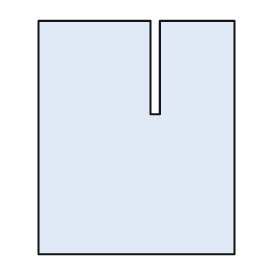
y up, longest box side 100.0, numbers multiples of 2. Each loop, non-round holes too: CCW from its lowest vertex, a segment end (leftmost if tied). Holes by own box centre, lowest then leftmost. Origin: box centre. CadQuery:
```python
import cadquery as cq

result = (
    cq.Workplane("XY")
    .moveTo(-42.0, -50.0)
    .lineTo(42.0, -50.0)
    .lineTo(42.0, 50.0)
    .lineTo(10.0, 50.0)
    .lineTo(10.0, 10.0)
    .lineTo(6.0, 10.0)
    .lineTo(6.0, 50.0)
    .lineTo(-42.0, 50.0)
    .close()
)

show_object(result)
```